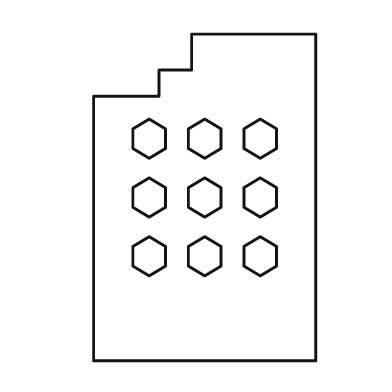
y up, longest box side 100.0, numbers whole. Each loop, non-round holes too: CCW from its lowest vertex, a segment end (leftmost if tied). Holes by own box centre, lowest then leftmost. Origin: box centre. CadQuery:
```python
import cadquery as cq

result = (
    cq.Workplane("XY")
    .moveTo(-34.0, -50.0)
    .lineTo(34.0, -50.0)
    .lineTo(34.0, 50.0)
    .lineTo(-4.0, 50.0)
    .lineTo(-4.0, 39.0)
    .lineTo(-14.0, 39.0)
    .lineTo(-14.0, 31.0)
    .lineTo(-34.0, 31.0)
    .close()
    .moveTo(-17.0, -24.0)
    .lineTo(-12.0, -21.0)
    .lineTo(-12.0, -15.0)
    .lineTo(-17.0, -12.0)
    .lineTo(-22.0, -15.0)
    .lineTo(-22.0, -21.0)
    .close()
    .moveTo(0.0, -24.0)
    .lineTo(5.0, -21.0)
    .lineTo(5.0, -15.0)
    .lineTo(0.0, -12.0)
    .lineTo(-5.0, -15.0)
    .lineTo(-5.0, -21.0)
    .close()
    .moveTo(17.0, -24.0)
    .lineTo(22.0, -21.0)
    .lineTo(22.0, -15.0)
    .lineTo(17.0, -12.0)
    .lineTo(12.0, -15.0)
    .lineTo(12.0, -21.0)
    .close()
    .moveTo(-17.0, -6.0)
    .lineTo(-12.0, -3.0)
    .lineTo(-12.0, 3.0)
    .lineTo(-17.0, 6.0)
    .lineTo(-22.0, 3.0)
    .lineTo(-22.0, -3.0)
    .close()
    .moveTo(0.0, -6.0)
    .lineTo(5.0, -3.0)
    .lineTo(5.0, 3.0)
    .lineTo(0.0, 6.0)
    .lineTo(-5.0, 3.0)
    .lineTo(-5.0, -3.0)
    .close()
    .moveTo(17.0, -6.0)
    .lineTo(22.0, -3.0)
    .lineTo(22.0, 3.0)
    .lineTo(17.0, 6.0)
    .lineTo(12.0, 3.0)
    .lineTo(12.0, -3.0)
    .close()
    .moveTo(-17.0, 12.0)
    .lineTo(-12.0, 15.0)
    .lineTo(-12.0, 21.0)
    .lineTo(-17.0, 24.0)
    .lineTo(-22.0, 21.0)
    .lineTo(-22.0, 15.0)
    .close()
    .moveTo(0.0, 12.0)
    .lineTo(5.0, 15.0)
    .lineTo(5.0, 21.0)
    .lineTo(0.0, 24.0)
    .lineTo(-5.0, 21.0)
    .lineTo(-5.0, 15.0)
    .close()
    .moveTo(17.0, 12.0)
    .lineTo(22.0, 15.0)
    .lineTo(22.0, 21.0)
    .lineTo(17.0, 24.0)
    .lineTo(12.0, 21.0)
    .lineTo(12.0, 15.0)
    .close()
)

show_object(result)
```